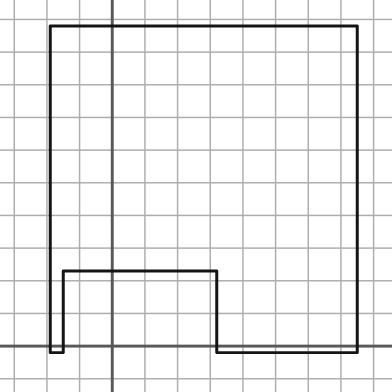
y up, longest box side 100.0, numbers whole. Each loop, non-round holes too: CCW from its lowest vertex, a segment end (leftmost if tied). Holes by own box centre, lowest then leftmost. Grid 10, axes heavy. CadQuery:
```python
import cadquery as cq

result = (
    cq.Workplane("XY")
    .moveTo(-19.0, -2.0)
    .lineTo(-15.0, -2.0)
    .lineTo(-15.0, 23.0)
    .lineTo(32.0, 23.0)
    .lineTo(32.0, -2.0)
    .lineTo(75.0, -2.0)
    .lineTo(75.0, 98.0)
    .lineTo(-19.0, 98.0)
    .close()
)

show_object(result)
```